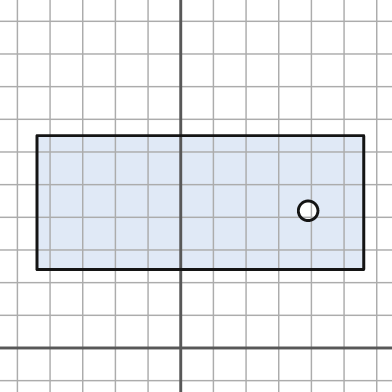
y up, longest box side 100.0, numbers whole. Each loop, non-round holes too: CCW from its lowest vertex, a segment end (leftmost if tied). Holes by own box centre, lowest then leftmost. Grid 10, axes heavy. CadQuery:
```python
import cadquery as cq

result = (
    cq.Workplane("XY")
    .moveTo(-44.0, 24.0)
    .lineTo(56.0, 24.0)
    .lineTo(56.0, 65.0)
    .lineTo(-44.0, 65.0)
    .close()
    .moveTo(39.0, 42.0)
    .circle(3.0)
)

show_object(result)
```